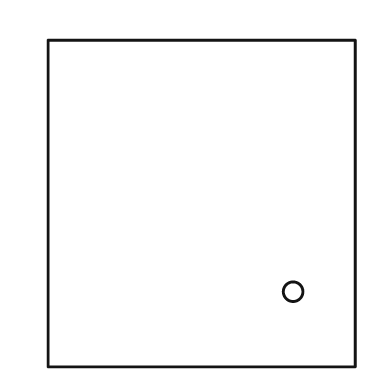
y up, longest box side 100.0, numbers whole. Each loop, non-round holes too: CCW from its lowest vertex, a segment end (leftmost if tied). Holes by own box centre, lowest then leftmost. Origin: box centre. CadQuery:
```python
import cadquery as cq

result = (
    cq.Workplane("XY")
    .moveTo(-47.0, -50.0)
    .lineTo(47.0, -50.0)
    .lineTo(47.0, 50.0)
    .lineTo(-47.0, 50.0)
    .close()
    .moveTo(28.0, -27.0)
    .circle(3.0)
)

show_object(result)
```